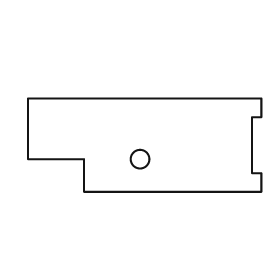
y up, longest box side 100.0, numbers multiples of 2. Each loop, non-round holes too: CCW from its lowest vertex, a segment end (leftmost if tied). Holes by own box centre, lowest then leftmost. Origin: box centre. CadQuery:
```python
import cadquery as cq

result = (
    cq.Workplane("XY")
    .moveTo(-26.0, -20.0)
    .lineTo(50.0, -20.0)
    .lineTo(50.0, -12.0)
    .lineTo(46.0, -12.0)
    .lineTo(46.0, 12.0)
    .lineTo(50.0, 12.0)
    .lineTo(50.0, 20.0)
    .lineTo(-50.0, 20.0)
    .lineTo(-50.0, -6.0)
    .lineTo(-26.0, -6.0)
    .close()
    .moveTo(-2.0, -6.0)
    .circle(4.0)
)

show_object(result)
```